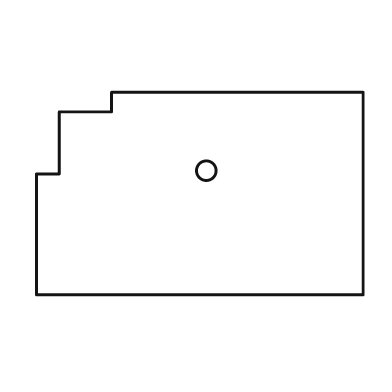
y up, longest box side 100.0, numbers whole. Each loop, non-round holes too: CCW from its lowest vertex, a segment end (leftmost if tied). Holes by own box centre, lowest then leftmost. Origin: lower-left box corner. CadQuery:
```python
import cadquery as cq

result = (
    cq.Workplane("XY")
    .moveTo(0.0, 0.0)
    .lineTo(100.0, 0.0)
    .lineTo(100.0, 62.0)
    .lineTo(23.0, 62.0)
    .lineTo(23.0, 56.0)
    .lineTo(7.0, 56.0)
    .lineTo(7.0, 37.0)
    .lineTo(0.0, 37.0)
    .close()
    .moveTo(52.0, 38.0)
    .circle(3.0)
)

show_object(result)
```